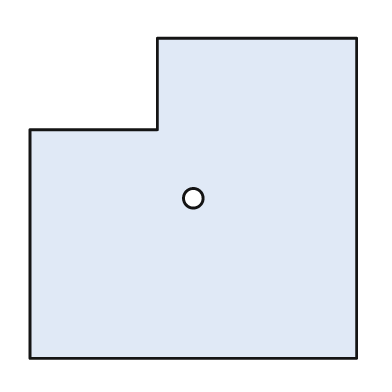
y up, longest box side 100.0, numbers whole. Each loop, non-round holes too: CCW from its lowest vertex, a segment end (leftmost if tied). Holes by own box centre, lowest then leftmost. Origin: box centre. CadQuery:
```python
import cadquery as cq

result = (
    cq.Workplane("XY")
    .moveTo(-50.0, -49.0)
    .lineTo(50.0, -49.0)
    .lineTo(50.0, 49.0)
    .lineTo(-11.0, 49.0)
    .lineTo(-11.0, 21.0)
    .lineTo(-50.0, 21.0)
    .close()
    .moveTo(0.0, 0.0)
    .circle(3.0)
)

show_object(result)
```